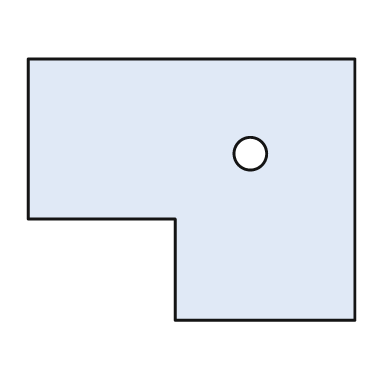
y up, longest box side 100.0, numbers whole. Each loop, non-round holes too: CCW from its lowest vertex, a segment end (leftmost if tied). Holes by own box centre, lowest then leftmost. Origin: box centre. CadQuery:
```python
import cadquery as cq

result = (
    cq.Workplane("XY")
    .moveTo(-5.0, -40.0)
    .lineTo(50.0, -40.0)
    .lineTo(50.0, 40.0)
    .lineTo(-50.0, 40.0)
    .lineTo(-50.0, -9.0)
    .lineTo(-5.0, -9.0)
    .close()
    .moveTo(18.0, 11.0)
    .circle(5.0)
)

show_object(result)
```